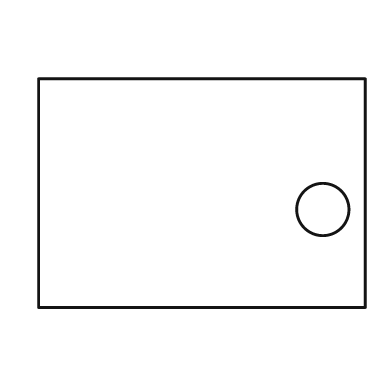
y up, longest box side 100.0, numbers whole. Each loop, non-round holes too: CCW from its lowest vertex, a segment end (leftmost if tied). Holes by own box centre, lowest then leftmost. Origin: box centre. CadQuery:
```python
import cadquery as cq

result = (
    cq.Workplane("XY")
    .moveTo(-50.0, -35.0)
    .lineTo(50.0, -35.0)
    .lineTo(50.0, 35.0)
    .lineTo(-50.0, 35.0)
    .close()
    .moveTo(37.0, -5.0)
    .circle(8.0)
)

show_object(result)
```